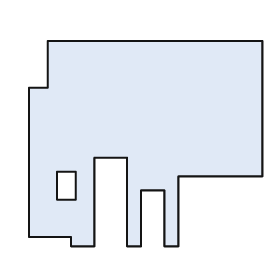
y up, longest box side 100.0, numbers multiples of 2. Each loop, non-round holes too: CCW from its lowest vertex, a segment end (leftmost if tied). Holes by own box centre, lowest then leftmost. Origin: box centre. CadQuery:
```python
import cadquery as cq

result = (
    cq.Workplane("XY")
    .moveTo(-32.0, -44.0)
    .lineTo(-22.0, -44.0)
    .lineTo(-22.0, -6.0)
    .lineTo(-8.0, -6.0)
    .lineTo(-8.0, -44.0)
    .lineTo(-2.0, -44.0)
    .lineTo(-2.0, -20.0)
    .lineTo(8.0, -20.0)
    .lineTo(8.0, -44.0)
    .lineTo(14.0, -44.0)
    .lineTo(14.0, -14.0)
    .lineTo(50.0, -14.0)
    .lineTo(50.0, 44.0)
    .lineTo(-42.0, 44.0)
    .lineTo(-42.0, 24.0)
    .lineTo(-50.0, 24.0)
    .lineTo(-50.0, -40.0)
    .lineTo(-32.0, -40.0)
    .close()
    .moveTo(-38.0, -24.0)
    .lineTo(-30.0, -24.0)
    .lineTo(-30.0, -12.0)
    .lineTo(-38.0, -12.0)
    .close()
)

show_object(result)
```